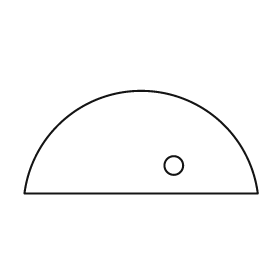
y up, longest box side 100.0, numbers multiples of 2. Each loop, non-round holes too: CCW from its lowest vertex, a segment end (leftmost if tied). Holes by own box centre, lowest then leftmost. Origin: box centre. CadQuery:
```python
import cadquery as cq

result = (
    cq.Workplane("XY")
    .moveTo(-50.0, -22.0)
    .lineTo(50.0, -22.0)
    .threePointArc((0.0, 22.0), (-50.0, -22.0))
    .close()
    .moveTo(14.0, -10.0)
    .circle(4.0)
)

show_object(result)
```